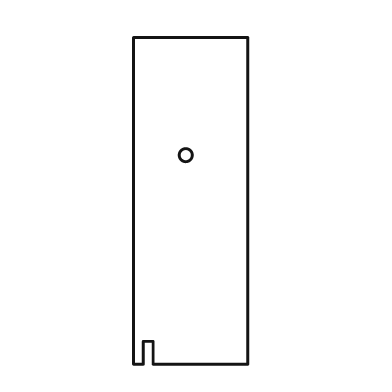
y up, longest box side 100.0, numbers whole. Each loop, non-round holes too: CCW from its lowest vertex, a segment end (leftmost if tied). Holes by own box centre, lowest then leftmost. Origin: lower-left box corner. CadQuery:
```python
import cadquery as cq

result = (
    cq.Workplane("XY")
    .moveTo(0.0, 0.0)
    .lineTo(3.0, 0.0)
    .lineTo(3.0, 7.0)
    .lineTo(6.0, 7.0)
    .lineTo(6.0, 0.0)
    .lineTo(35.0, 0.0)
    .lineTo(35.0, 100.0)
    .lineTo(0.0, 100.0)
    .close()
    .moveTo(16.0, 64.0)
    .circle(2.0)
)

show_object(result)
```